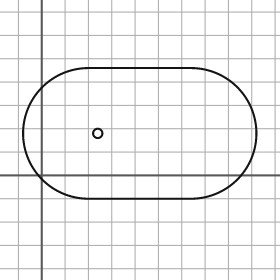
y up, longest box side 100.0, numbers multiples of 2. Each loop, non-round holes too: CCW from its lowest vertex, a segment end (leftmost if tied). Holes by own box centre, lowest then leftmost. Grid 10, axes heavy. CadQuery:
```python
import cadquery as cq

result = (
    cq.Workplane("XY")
    .moveTo(20.0, -10.0)
    .lineTo(64.0, -10.0)
    .threePointArc((92.0, 18.0), (64.0, 46.0))
    .lineTo(20.0, 46.0)
    .threePointArc((-8.0, 18.0), (20.0, -10.0))
    .close()
    .moveTo(24.0, 18.0)
    .circle(2.0)
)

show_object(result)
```